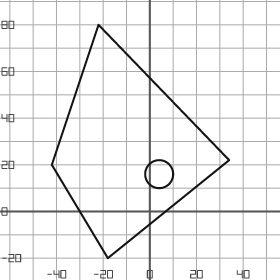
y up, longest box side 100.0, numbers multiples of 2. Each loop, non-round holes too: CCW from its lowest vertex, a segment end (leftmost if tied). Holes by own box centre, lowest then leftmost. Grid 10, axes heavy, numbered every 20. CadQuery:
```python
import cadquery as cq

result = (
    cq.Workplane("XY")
    .moveTo(-18.0, -20.0)
    .lineTo(34.0, 22.0)
    .lineTo(-22.0, 80.0)
    .lineTo(-42.0, 20.0)
    .close()
    .moveTo(4.0, 16.0)
    .circle(6.0)
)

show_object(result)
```